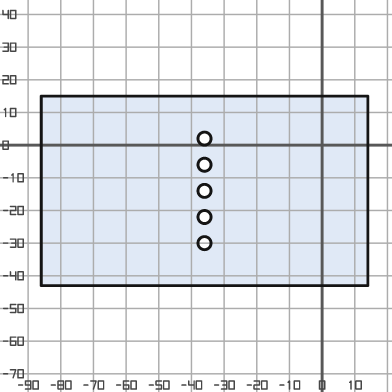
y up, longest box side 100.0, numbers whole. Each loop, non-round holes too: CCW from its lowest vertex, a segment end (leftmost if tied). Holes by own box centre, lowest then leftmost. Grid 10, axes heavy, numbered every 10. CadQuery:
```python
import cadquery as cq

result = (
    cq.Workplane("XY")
    .moveTo(-86.0, -43.0)
    .lineTo(14.0, -43.0)
    .lineTo(14.0, 15.0)
    .lineTo(-86.0, 15.0)
    .close()
    .moveTo(-36.0, -30.0)
    .circle(2.0)
    .moveTo(-36.0, -22.0)
    .circle(2.0)
    .moveTo(-36.0, -14.0)
    .circle(2.0)
    .moveTo(-36.0, -6.0)
    .circle(2.0)
    .moveTo(-36.0, 2.0)
    .circle(2.0)
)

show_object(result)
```